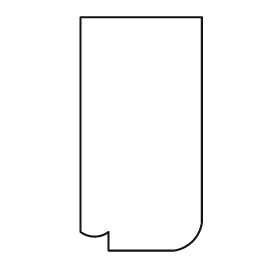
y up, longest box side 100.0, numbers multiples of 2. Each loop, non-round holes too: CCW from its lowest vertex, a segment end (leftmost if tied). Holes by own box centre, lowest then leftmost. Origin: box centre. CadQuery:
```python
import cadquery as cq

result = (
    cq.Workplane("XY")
    .moveTo(-14.0, -50.0)
    .lineTo(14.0, -50.0)
    .threePointArc((22.0, -46.0), (26.0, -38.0))
    .lineTo(26.0, 50.0)
    .lineTo(-26.0, 50.0)
    .lineTo(-26.0, -42.0)
    .threePointArc((-20.0, -44.0), (-14.0, -42.0))
    .close()
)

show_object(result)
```